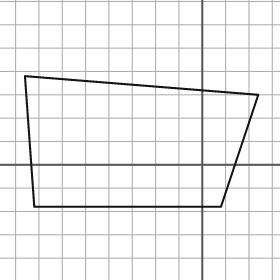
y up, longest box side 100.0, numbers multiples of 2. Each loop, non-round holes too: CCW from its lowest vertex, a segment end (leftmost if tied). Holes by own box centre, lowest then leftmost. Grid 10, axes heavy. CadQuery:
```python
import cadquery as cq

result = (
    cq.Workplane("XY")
    .moveTo(-72.0, -18.0)
    .lineTo(8.0, -18.0)
    .lineTo(24.0, 30.0)
    .lineTo(-76.0, 38.0)
    .close()
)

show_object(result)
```